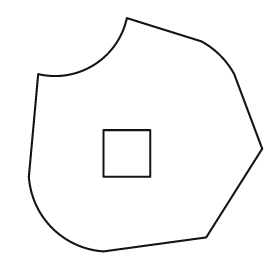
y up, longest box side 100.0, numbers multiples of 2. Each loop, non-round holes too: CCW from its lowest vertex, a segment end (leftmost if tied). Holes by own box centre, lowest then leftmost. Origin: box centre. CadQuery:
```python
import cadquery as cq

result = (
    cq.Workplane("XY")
    .moveTo(-18.0, -50.0)
    .lineTo(26.0, -44.0)
    .lineTo(50.0, -6.0)
    .lineTo(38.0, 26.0)
    .threePointArc((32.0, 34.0), (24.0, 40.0))
    .lineTo(-8.0, 50.0)
    .threePointArc((-22.0, 30.0), (-46.0, 26.0))
    .lineTo(-50.0, -18.0)
    .threePointArc((-40.0, -40.0), (-18.0, -50.0))
    .close()
    .moveTo(-18.0, -18.0)
    .lineTo(2.0, -18.0)
    .lineTo(2.0, 2.0)
    .lineTo(-18.0, 2.0)
    .close()
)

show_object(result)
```